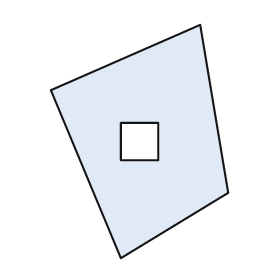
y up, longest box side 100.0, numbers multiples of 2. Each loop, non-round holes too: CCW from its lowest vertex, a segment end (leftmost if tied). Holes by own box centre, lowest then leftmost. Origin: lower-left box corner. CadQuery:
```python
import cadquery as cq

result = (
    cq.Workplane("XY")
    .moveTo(30.0, 0.0)
    .lineTo(76.0, 28.0)
    .lineTo(64.0, 100.0)
    .lineTo(0.0, 72.0)
    .close()
    .moveTo(30.0, 42.0)
    .lineTo(46.0, 42.0)
    .lineTo(46.0, 58.0)
    .lineTo(30.0, 58.0)
    .close()
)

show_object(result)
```